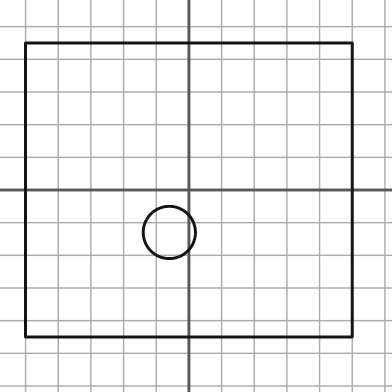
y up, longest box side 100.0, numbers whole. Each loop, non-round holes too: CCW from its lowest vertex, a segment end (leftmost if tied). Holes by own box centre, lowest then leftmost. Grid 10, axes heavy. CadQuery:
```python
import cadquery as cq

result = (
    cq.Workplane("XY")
    .moveTo(-50.0, -45.0)
    .lineTo(50.0, -45.0)
    .lineTo(50.0, 45.0)
    .lineTo(-50.0, 45.0)
    .close()
    .moveTo(-6.0, -13.0)
    .circle(8.0)
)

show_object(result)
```